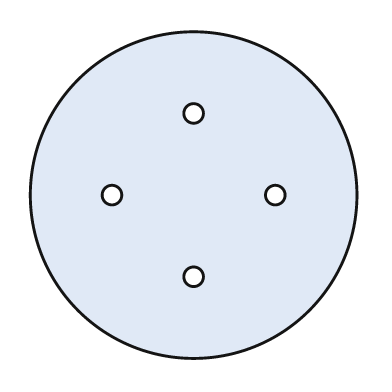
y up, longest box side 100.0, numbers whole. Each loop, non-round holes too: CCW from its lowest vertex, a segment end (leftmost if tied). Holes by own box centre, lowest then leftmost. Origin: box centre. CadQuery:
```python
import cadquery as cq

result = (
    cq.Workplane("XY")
    .moveTo(0.0, 0.0)
    .circle(50.0)
    .moveTo(0.0, -25.0)
    .circle(3.0)
    .moveTo(-25.0, 0.0)
    .circle(3.0)
    .moveTo(25.0, 0.0)
    .circle(3.0)
    .moveTo(0.0, 25.0)
    .circle(3.0)
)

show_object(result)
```